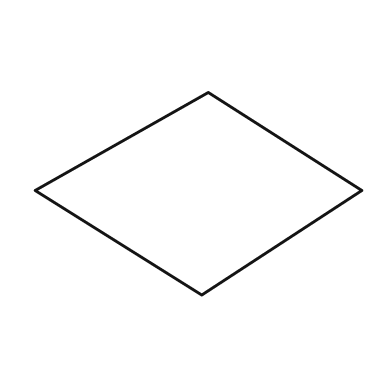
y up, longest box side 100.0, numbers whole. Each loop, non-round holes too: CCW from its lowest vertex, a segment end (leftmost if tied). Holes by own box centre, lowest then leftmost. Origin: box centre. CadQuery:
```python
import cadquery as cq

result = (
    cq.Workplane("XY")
    .moveTo(1.0, -31.0)
    .lineTo(50.0, 1.0)
    .lineTo(3.0, 31.0)
    .lineTo(-50.0, 1.0)
    .close()
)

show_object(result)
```